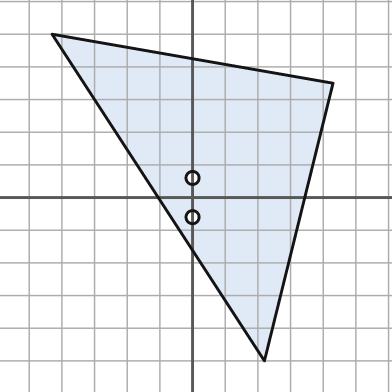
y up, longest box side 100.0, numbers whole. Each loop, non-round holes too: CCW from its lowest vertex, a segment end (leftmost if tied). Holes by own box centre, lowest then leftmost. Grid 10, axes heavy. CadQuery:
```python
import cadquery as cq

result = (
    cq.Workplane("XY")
    .moveTo(22.0, -50.0)
    .lineTo(43.0, 35.0)
    .lineTo(-43.0, 50.0)
    .close()
    .moveTo(0.0, -6.0)
    .circle(2.0)
    .moveTo(0.0, 6.0)
    .circle(2.0)
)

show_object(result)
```